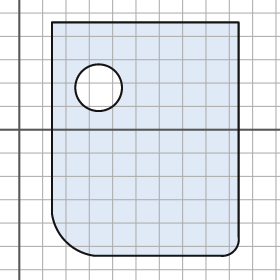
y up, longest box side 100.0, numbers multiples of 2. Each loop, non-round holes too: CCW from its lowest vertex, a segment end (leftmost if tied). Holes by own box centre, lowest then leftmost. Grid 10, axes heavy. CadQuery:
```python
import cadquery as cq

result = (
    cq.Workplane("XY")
    .moveTo(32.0, -54.0)
    .lineTo(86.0, -54.0)
    .threePointArc((92.0, -52.0), (94.0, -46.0))
    .lineTo(94.0, 46.0)
    .lineTo(14.0, 46.0)
    .lineTo(14.0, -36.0)
    .threePointArc((20.0, -48.0), (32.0, -54.0))
    .close()
    .moveTo(34.0, 18.0)
    .circle(10.0)
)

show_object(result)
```